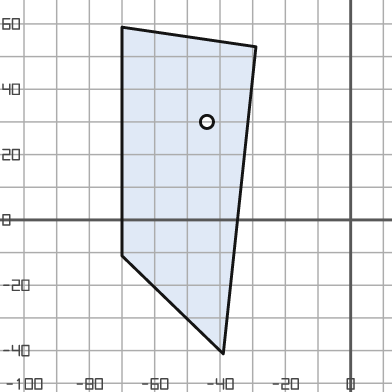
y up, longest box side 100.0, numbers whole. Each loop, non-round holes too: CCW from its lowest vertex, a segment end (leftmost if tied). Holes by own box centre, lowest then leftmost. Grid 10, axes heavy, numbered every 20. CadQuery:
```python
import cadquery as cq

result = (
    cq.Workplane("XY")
    .moveTo(-39.0, -41.0)
    .lineTo(-29.0, 53.0)
    .lineTo(-70.0, 59.0)
    .lineTo(-70.0, -11.0)
    .close()
    .moveTo(-44.0, 30.0)
    .circle(2.0)
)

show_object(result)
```